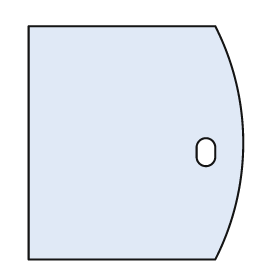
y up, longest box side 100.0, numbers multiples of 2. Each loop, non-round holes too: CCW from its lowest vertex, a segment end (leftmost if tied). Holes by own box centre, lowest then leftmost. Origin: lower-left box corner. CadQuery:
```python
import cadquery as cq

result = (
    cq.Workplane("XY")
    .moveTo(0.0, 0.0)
    .lineTo(80.0, 0.0)
    .threePointArc((92.0, 50.0), (80.0, 100.0))
    .lineTo(0.0, 100.0)
    .close()
    .moveTo(72.0, 44.0)
    .threePointArc((76.0, 40.0), (80.0, 44.0))
    .lineTo(80.0, 48.0)
    .threePointArc((76.0, 52.0), (72.0, 48.0))
    .close()
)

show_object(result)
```